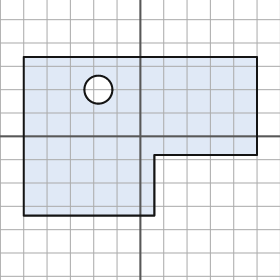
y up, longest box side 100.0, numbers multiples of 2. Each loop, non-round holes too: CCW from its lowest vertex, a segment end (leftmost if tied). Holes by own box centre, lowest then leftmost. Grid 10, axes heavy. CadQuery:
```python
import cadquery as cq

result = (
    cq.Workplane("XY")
    .moveTo(-50.0, -34.0)
    .lineTo(6.0, -34.0)
    .lineTo(6.0, -8.0)
    .lineTo(50.0, -8.0)
    .lineTo(50.0, 34.0)
    .lineTo(-50.0, 34.0)
    .close()
    .moveTo(-18.0, 20.0)
    .circle(6.0)
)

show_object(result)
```